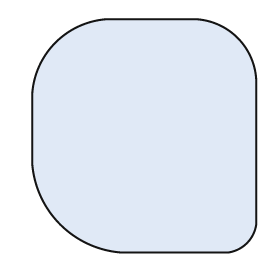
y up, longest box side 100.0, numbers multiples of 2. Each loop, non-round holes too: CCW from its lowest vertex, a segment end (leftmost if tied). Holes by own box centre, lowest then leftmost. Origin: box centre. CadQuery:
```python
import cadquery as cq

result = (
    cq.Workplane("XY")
    .moveTo(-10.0, -50.0)
    .lineTo(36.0, -50.0)
    .threePointArc((44.0, -46.0), (48.0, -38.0))
    .lineTo(48.0, 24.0)
    .threePointArc((40.0, 42.0), (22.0, 50.0))
    .lineTo(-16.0, 50.0)
    .threePointArc((-38.0, 40.0), (-48.0, 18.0))
    .lineTo(-48.0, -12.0)
    .threePointArc((-36.0, -38.0), (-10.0, -50.0))
    .close()
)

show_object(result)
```